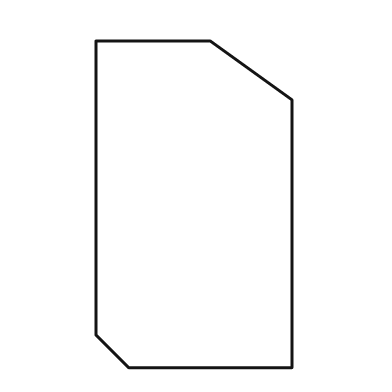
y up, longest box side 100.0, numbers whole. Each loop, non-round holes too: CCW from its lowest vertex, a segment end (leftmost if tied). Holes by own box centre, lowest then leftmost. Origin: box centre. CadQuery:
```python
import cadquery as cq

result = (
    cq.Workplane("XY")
    .moveTo(-20.0, -50.0)
    .lineTo(30.0, -50.0)
    .lineTo(30.0, 32.0)
    .lineTo(5.0, 50.0)
    .lineTo(-30.0, 50.0)
    .lineTo(-30.0, -40.0)
    .close()
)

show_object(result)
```